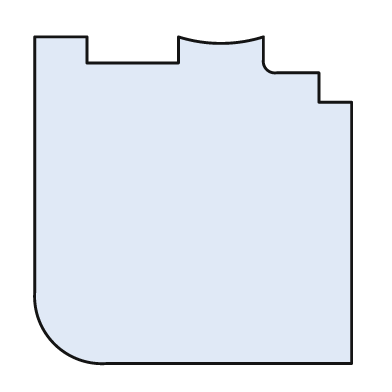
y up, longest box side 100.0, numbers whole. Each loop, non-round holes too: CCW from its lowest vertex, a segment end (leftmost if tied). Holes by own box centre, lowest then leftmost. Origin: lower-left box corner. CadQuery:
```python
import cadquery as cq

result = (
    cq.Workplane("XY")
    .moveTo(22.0, 0.0)
    .lineTo(97.0, 0.0)
    .lineTo(97.0, 80.0)
    .lineTo(87.0, 80.0)
    .lineTo(87.0, 89.0)
    .lineTo(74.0, 89.0)
    .threePointArc((71.0, 90.0), (70.0, 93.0))
    .lineTo(70.0, 100.0)
    .threePointArc((57.0, 98.0), (44.0, 100.0))
    .lineTo(44.0, 92.0)
    .lineTo(16.0, 92.0)
    .lineTo(16.0, 100.0)
    .lineTo(0.0, 100.0)
    .lineTo(0.0, 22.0)
    .threePointArc((6.0, 6.0), (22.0, 0.0))
    .close()
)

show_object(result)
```